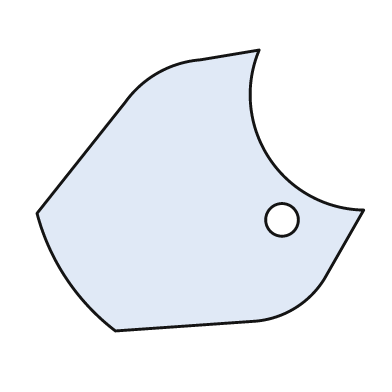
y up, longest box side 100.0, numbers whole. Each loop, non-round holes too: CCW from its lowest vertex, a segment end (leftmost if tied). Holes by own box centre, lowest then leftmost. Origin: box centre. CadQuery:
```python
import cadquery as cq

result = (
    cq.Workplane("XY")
    .moveTo(-26.0, -43.0)
    .lineTo(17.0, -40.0)
    .threePointArc((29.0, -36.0), (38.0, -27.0))
    .lineTo(50.0, -6.0)
    .threePointArc((21.0, 10.0), (18.0, 43.0))
    .lineTo(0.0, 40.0)
    .threePointArc((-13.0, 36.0), (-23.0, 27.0))
    .lineTo(-50.0, -7.0)
    .threePointArc((-41.0, -27.0), (-26.0, -43.0))
    .close()
    .moveTo(25.0, -9.0)
    .circle(5.0)
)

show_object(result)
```